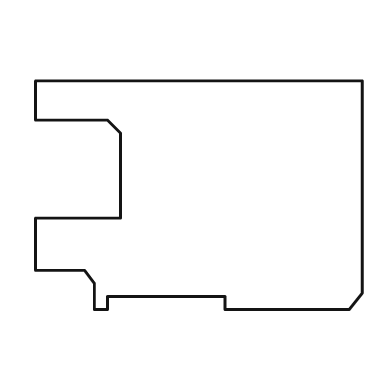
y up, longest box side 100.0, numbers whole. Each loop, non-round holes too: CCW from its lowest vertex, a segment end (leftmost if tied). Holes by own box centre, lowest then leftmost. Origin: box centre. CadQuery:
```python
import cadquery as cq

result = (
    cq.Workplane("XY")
    .moveTo(-32.0, -35.0)
    .lineTo(-28.0, -35.0)
    .lineTo(-28.0, -31.0)
    .lineTo(8.0, -31.0)
    .lineTo(8.0, -35.0)
    .lineTo(46.0, -35.0)
    .lineTo(50.0, -30.0)
    .lineTo(50.0, 35.0)
    .lineTo(-50.0, 35.0)
    .lineTo(-50.0, 23.0)
    .lineTo(-28.0, 23.0)
    .lineTo(-24.0, 19.0)
    .lineTo(-24.0, -7.0)
    .lineTo(-50.0, -7.0)
    .lineTo(-50.0, -23.0)
    .lineTo(-35.0, -23.0)
    .lineTo(-32.0, -27.0)
    .close()
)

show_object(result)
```